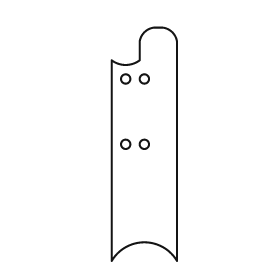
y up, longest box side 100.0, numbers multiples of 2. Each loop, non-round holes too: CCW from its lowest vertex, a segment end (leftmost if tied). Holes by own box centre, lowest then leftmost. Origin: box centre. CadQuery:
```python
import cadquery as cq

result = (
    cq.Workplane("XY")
    .moveTo(-14.0, -50.0)
    .threePointArc((0.0, -42.0), (14.0, -50.0))
    .lineTo(14.0, 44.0)
    .threePointArc((12.0, 48.0), (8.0, 50.0))
    .lineTo(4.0, 50.0)
    .threePointArc((0.0, 48.0), (-2.0, 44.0))
    .lineTo(-2.0, 36.0)
    .threePointArc((-8.0, 34.0), (-14.0, 36.0))
    .close()
    .moveTo(-8.0, 0.0)
    .circle(2.0)
    .moveTo(0.0, 0.0)
    .circle(2.0)
    .moveTo(-8.0, 28.0)
    .circle(2.0)
    .moveTo(0.0, 28.0)
    .circle(2.0)
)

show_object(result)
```